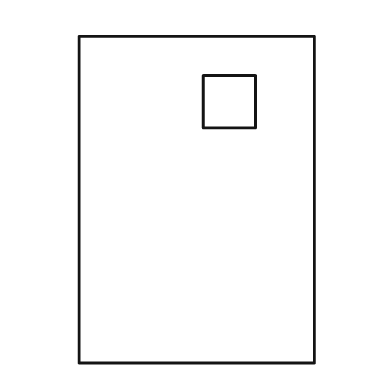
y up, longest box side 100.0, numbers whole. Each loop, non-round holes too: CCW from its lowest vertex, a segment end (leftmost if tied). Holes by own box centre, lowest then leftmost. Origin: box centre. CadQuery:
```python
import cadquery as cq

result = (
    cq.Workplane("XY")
    .moveTo(-36.0, -50.0)
    .lineTo(36.0, -50.0)
    .lineTo(36.0, 50.0)
    .lineTo(-36.0, 50.0)
    .close()
    .moveTo(2.0, 22.0)
    .lineTo(18.0, 22.0)
    .lineTo(18.0, 38.0)
    .lineTo(2.0, 38.0)
    .close()
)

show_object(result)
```